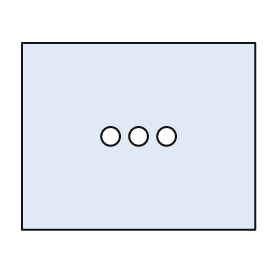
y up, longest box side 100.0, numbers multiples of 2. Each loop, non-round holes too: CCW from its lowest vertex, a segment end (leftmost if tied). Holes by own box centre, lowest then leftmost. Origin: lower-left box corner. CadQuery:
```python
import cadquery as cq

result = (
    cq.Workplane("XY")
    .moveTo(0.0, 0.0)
    .lineTo(100.0, 0.0)
    .lineTo(100.0, 80.0)
    .lineTo(0.0, 80.0)
    .close()
    .moveTo(38.0, 40.0)
    .circle(4.0)
    .moveTo(50.0, 40.0)
    .circle(4.0)
    .moveTo(62.0, 40.0)
    .circle(4.0)
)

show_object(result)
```